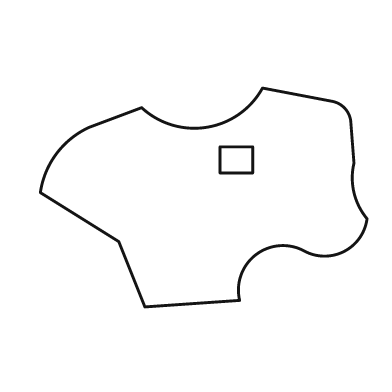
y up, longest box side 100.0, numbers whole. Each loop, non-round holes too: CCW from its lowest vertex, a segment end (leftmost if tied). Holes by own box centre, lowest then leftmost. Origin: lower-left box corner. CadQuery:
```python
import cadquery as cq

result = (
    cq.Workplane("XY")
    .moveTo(32.0, 0.0)
    .lineTo(61.0, 2.0)
    .threePointArc((66.0, 16.0), (81.0, 17.0))
    .threePointArc((93.0, 17.0), (100.0, 27.0))
    .threePointArc((96.0, 35.0), (96.0, 44.0))
    .lineTo(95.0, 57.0)
    .threePointArc((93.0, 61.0), (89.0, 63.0))
    .lineTo(68.0, 67.0)
    .threePointArc((51.0, 55.0), (31.0, 61.0))
    .lineTo(15.0, 55.0)
    .threePointArc((5.0, 47.0), (0.0, 35.0))
    .lineTo(24.0, 20.0)
    .close()
    .moveTo(55.0, 41.0)
    .lineTo(65.0, 41.0)
    .lineTo(65.0, 49.0)
    .lineTo(55.0, 49.0)
    .close()
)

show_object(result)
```